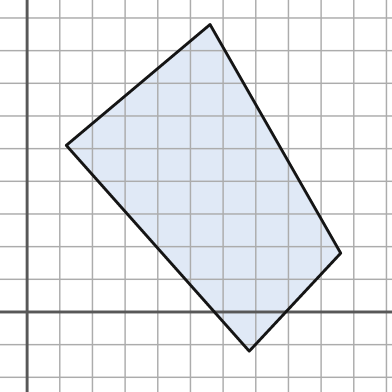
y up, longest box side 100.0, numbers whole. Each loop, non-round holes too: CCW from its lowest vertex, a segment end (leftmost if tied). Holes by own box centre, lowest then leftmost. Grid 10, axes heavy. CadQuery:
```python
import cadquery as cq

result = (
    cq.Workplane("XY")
    .moveTo(68.0, -12.0)
    .lineTo(96.0, 18.0)
    .lineTo(56.0, 88.0)
    .lineTo(12.0, 51.0)
    .close()
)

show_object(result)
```